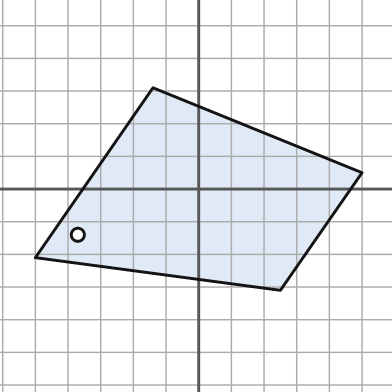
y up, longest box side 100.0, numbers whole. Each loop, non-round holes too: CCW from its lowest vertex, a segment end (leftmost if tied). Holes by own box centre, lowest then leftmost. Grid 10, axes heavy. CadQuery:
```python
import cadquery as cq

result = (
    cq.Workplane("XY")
    .moveTo(25.0, -31.0)
    .lineTo(50.0, 5.0)
    .lineTo(-14.0, 31.0)
    .lineTo(-50.0, -21.0)
    .close()
    .moveTo(-37.0, -14.0)
    .circle(2.0)
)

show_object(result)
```